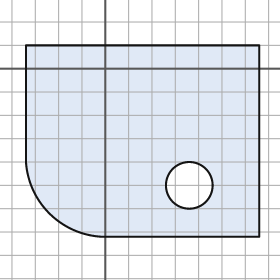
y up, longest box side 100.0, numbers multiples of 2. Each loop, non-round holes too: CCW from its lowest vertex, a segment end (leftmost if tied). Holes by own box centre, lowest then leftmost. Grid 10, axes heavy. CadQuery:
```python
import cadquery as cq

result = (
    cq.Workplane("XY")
    .moveTo(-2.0, -72.0)
    .lineTo(66.0, -72.0)
    .lineTo(66.0, 10.0)
    .lineTo(-34.0, 10.0)
    .lineTo(-34.0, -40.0)
    .threePointArc((-24.0, -62.0), (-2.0, -72.0))
    .close()
    .moveTo(36.0, -50.0)
    .circle(10.0)
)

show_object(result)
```